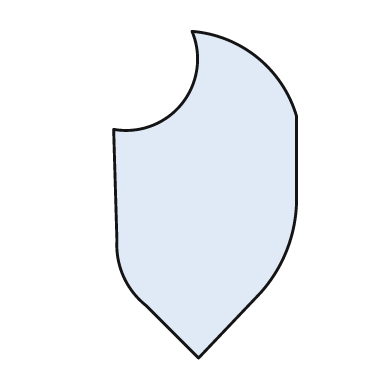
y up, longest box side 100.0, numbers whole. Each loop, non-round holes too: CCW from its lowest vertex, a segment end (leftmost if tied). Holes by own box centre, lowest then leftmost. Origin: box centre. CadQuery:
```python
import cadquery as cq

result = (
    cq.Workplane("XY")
    .moveTo(-2.0, -50.0)
    .lineTo(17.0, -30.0)
    .threePointArc((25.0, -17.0), (28.0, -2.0))
    .lineTo(28.0, 24.0)
    .threePointArc((16.0, 42.0), (-4.0, 50.0))
    .threePointArc((-7.0, 28.0), (-28.0, 20.0))
    .lineTo(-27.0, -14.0)
    .threePointArc((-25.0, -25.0), (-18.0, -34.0))
    .close()
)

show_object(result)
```